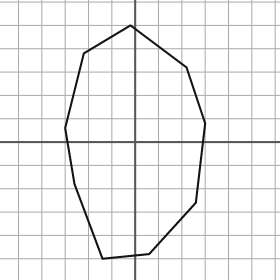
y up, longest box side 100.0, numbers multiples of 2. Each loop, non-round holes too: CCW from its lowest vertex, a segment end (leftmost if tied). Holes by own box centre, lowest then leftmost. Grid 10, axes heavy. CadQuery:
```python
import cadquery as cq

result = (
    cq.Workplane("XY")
    .moveTo(-14.0, -50.0)
    .lineTo(6.0, -48.0)
    .lineTo(26.0, -26.0)
    .lineTo(30.0, 8.0)
    .lineTo(22.0, 32.0)
    .lineTo(-2.0, 50.0)
    .lineTo(-22.0, 38.0)
    .lineTo(-30.0, 6.0)
    .lineTo(-26.0, -18.0)
    .close()
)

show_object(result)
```